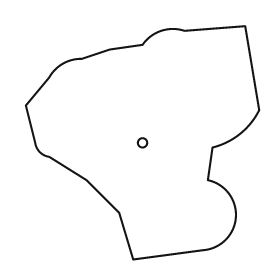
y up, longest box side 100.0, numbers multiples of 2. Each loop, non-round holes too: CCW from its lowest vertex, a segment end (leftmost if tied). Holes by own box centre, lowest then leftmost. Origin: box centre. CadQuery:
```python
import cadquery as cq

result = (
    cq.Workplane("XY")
    .moveTo(-4.0, -50.0)
    .lineTo(26.0, -46.0)
    .threePointArc((40.0, -32.0), (28.0, -16.0))
    .lineTo(30.0, -2.0)
    .threePointArc((42.0, 4.0), (50.0, 14.0))
    .lineTo(44.0, 50.0)
    .lineTo(18.0, 48.0)
    .threePointArc((8.0, 48.0), (0.0, 42.0))
    .lineTo(-14.0, 40.0)
    .lineTo(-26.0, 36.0)
    .threePointArc((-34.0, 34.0), (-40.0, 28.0))
    .lineTo(-50.0, 16.0)
    .lineTo(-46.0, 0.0)
    .threePointArc((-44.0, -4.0), (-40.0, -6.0))
    .lineTo(-24.0, -16.0)
    .lineTo(-10.0, -30.0)
    .close()
    .moveTo(0.0, 0.0)
    .circle(2.0)
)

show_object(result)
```